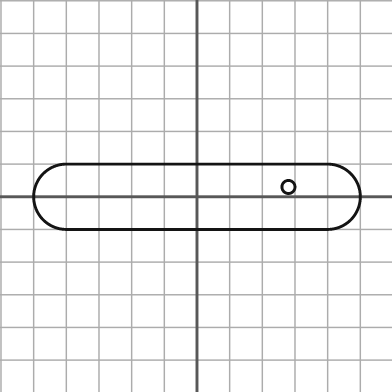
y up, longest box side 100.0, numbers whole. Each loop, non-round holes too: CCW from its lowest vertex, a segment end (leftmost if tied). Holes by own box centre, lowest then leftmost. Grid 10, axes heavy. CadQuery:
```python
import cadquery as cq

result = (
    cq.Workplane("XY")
    .moveTo(-40.0, -10.0)
    .lineTo(40.0, -10.0)
    .threePointArc((50.0, 0.0), (40.0, 10.0))
    .lineTo(-40.0, 10.0)
    .threePointArc((-50.0, 0.0), (-40.0, -10.0))
    .close()
    .moveTo(28.0, 3.0)
    .circle(2.0)
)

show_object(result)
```